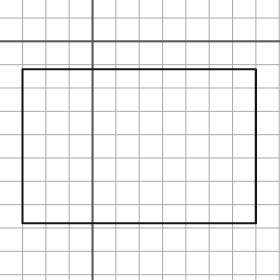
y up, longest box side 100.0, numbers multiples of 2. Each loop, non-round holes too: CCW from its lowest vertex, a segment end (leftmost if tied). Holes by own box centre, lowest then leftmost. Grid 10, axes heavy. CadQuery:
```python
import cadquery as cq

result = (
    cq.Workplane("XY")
    .moveTo(-30.0, -78.0)
    .lineTo(70.0, -78.0)
    .lineTo(70.0, -12.0)
    .lineTo(-30.0, -12.0)
    .close()
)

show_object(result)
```